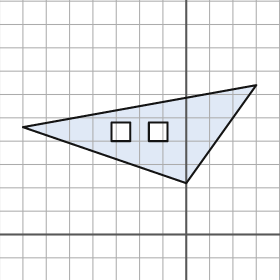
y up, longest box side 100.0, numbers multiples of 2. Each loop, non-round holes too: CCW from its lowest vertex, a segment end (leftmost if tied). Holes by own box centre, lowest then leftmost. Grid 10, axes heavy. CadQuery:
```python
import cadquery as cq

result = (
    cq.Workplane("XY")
    .moveTo(0.0, 22.0)
    .lineTo(30.0, 64.0)
    .lineTo(-70.0, 46.0)
    .close()
    .moveTo(-32.0, 40.0)
    .lineTo(-24.0, 40.0)
    .lineTo(-24.0, 48.0)
    .lineTo(-32.0, 48.0)
    .close()
    .moveTo(-16.0, 40.0)
    .lineTo(-8.0, 40.0)
    .lineTo(-8.0, 48.0)
    .lineTo(-16.0, 48.0)
    .close()
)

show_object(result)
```